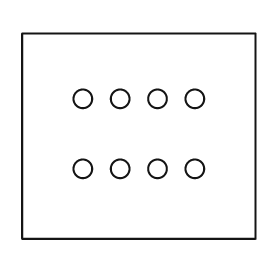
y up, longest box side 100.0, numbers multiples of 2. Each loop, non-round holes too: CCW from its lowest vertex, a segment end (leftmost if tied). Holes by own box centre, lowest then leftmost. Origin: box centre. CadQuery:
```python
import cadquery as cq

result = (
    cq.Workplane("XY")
    .moveTo(-50.0, -44.0)
    .lineTo(50.0, -44.0)
    .lineTo(50.0, 44.0)
    .lineTo(-50.0, 44.0)
    .close()
    .moveTo(-24.0, -14.0)
    .circle(4.0)
    .moveTo(-8.0, -14.0)
    .circle(4.0)
    .moveTo(8.0, -14.0)
    .circle(4.0)
    .moveTo(24.0, -14.0)
    .circle(4.0)
    .moveTo(-24.0, 16.0)
    .circle(4.0)
    .moveTo(-8.0, 16.0)
    .circle(4.0)
    .moveTo(8.0, 16.0)
    .circle(4.0)
    .moveTo(24.0, 16.0)
    .circle(4.0)
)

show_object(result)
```